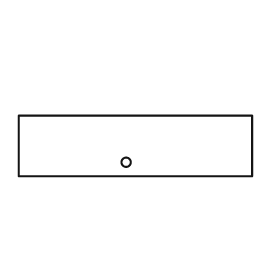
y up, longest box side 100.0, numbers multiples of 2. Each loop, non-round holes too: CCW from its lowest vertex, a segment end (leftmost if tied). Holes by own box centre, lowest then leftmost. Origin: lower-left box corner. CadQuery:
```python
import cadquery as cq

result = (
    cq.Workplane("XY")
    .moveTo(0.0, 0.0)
    .lineTo(100.0, 0.0)
    .lineTo(100.0, 26.0)
    .lineTo(0.0, 26.0)
    .close()
    .moveTo(46.0, 6.0)
    .circle(2.0)
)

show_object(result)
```